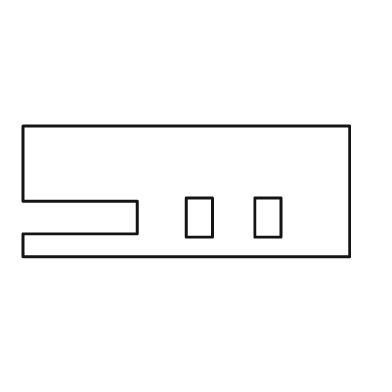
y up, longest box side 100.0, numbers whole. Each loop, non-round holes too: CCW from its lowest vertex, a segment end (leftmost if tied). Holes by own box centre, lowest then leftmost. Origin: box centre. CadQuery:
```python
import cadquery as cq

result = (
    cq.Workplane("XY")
    .moveTo(-50.0, -20.0)
    .lineTo(50.0, -20.0)
    .lineTo(50.0, 20.0)
    .lineTo(-50.0, 20.0)
    .lineTo(-50.0, -3.0)
    .lineTo(-15.0, -3.0)
    .lineTo(-15.0, -13.0)
    .lineTo(-50.0, -13.0)
    .close()
    .moveTo(0.0, -14.0)
    .lineTo(8.0, -14.0)
    .lineTo(8.0, -2.0)
    .lineTo(0.0, -2.0)
    .close()
    .moveTo(21.0, -14.0)
    .lineTo(29.0, -14.0)
    .lineTo(29.0, -2.0)
    .lineTo(21.0, -2.0)
    .close()
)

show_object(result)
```